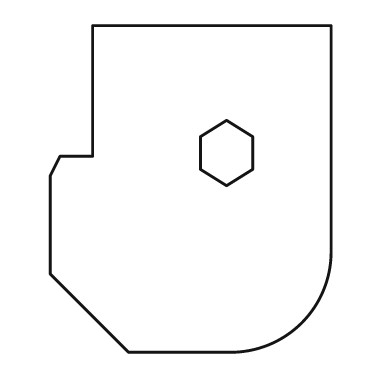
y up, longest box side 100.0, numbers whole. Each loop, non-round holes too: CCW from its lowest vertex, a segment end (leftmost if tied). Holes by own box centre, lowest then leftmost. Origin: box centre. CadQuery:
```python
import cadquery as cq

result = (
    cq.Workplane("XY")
    .moveTo(-19.0, -50.0)
    .lineTo(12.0, -50.0)
    .threePointArc((34.0, -41.0), (43.0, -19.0))
    .lineTo(43.0, 50.0)
    .lineTo(-30.0, 50.0)
    .lineTo(-30.0, 10.0)
    .lineTo(-40.0, 10.0)
    .lineTo(-43.0, 4.0)
    .lineTo(-43.0, -26.0)
    .close()
    .moveTo(11.0, 1.0)
    .lineTo(19.0, 6.0)
    .lineTo(19.0, 16.0)
    .lineTo(11.0, 21.0)
    .lineTo(3.0, 16.0)
    .lineTo(3.0, 6.0)
    .close()
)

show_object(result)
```